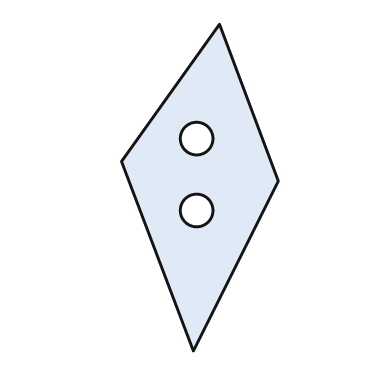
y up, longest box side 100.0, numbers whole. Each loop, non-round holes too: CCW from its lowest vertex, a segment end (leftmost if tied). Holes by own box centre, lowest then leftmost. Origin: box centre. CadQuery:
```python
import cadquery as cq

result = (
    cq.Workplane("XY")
    .moveTo(-2.0, -50.0)
    .lineTo(24.0, 2.0)
    .lineTo(6.0, 50.0)
    .lineTo(-24.0, 8.0)
    .close()
    .moveTo(-1.0, -7.0)
    .circle(5.0)
    .moveTo(-1.0, 15.0)
    .circle(5.0)
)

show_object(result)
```